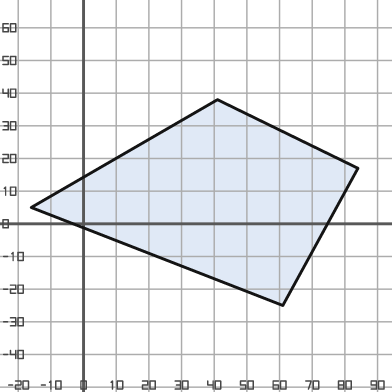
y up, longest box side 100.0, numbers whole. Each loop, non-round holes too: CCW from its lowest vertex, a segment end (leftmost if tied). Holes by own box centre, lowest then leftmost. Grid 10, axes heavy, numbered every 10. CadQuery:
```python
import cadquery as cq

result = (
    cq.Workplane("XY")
    .moveTo(61.0, -25.0)
    .lineTo(84.0, 17.0)
    .lineTo(41.0, 38.0)
    .lineTo(-16.0, 5.0)
    .close()
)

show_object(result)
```